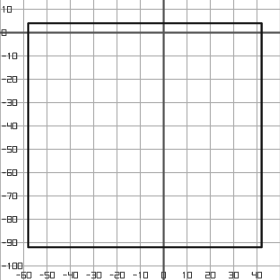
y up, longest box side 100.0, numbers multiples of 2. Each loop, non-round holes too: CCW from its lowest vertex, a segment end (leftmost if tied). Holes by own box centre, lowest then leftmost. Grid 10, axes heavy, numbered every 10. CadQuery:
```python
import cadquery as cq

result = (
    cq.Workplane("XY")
    .moveTo(-58.0, -92.0)
    .lineTo(42.0, -92.0)
    .lineTo(42.0, 4.0)
    .lineTo(-58.0, 4.0)
    .close()
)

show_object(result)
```